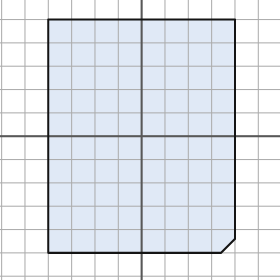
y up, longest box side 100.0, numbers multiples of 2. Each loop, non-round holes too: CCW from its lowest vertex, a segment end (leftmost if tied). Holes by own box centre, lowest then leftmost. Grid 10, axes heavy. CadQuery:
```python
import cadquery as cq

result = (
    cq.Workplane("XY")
    .moveTo(-40.0, -50.0)
    .lineTo(34.0, -50.0)
    .lineTo(40.0, -44.0)
    .lineTo(40.0, 50.0)
    .lineTo(-40.0, 50.0)
    .close()
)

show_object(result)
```